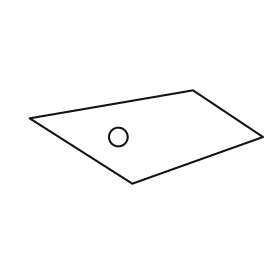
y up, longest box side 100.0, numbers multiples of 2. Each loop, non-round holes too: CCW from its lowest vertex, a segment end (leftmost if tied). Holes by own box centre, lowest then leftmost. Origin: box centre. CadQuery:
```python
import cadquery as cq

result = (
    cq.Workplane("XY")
    .moveTo(-6.0, -20.0)
    .lineTo(50.0, 0.0)
    .lineTo(20.0, 20.0)
    .lineTo(-50.0, 8.0)
    .close()
    .moveTo(-12.0, 0.0)
    .circle(4.0)
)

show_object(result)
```